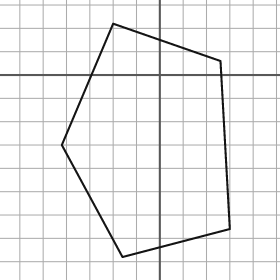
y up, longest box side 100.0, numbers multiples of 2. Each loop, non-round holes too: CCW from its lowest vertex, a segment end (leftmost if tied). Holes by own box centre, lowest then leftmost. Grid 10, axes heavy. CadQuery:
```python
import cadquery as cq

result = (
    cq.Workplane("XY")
    .moveTo(-16.0, -78.0)
    .lineTo(30.0, -66.0)
    .lineTo(26.0, 6.0)
    .lineTo(-20.0, 22.0)
    .lineTo(-42.0, -30.0)
    .close()
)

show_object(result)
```